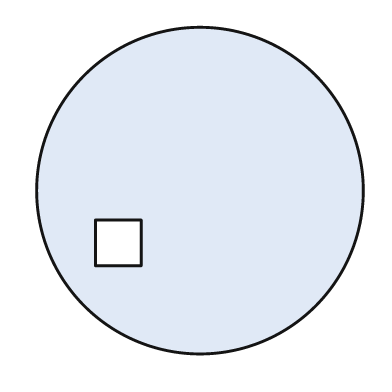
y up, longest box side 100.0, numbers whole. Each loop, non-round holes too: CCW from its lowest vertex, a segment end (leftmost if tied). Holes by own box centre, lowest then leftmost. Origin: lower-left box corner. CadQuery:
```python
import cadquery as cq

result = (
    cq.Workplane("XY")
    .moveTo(50.0, 50.0)
    .circle(50.0)
    .moveTo(18.0, 27.0)
    .lineTo(32.0, 27.0)
    .lineTo(32.0, 41.0)
    .lineTo(18.0, 41.0)
    .close()
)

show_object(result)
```